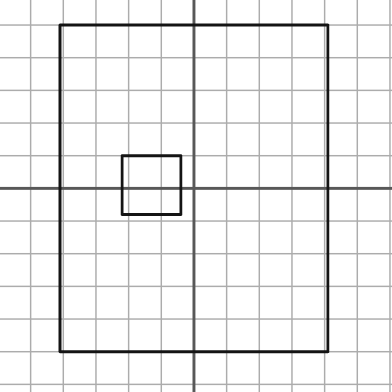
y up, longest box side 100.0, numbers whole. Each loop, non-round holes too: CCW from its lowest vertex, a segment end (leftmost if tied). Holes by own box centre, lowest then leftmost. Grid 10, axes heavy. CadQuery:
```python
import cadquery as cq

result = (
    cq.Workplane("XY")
    .moveTo(-41.0, -50.0)
    .lineTo(41.0, -50.0)
    .lineTo(41.0, 50.0)
    .lineTo(-41.0, 50.0)
    .close()
    .moveTo(-22.0, -8.0)
    .lineTo(-4.0, -8.0)
    .lineTo(-4.0, 10.0)
    .lineTo(-22.0, 10.0)
    .close()
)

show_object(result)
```